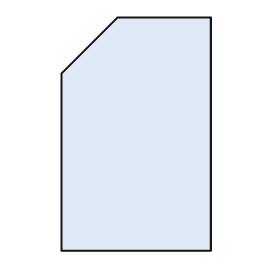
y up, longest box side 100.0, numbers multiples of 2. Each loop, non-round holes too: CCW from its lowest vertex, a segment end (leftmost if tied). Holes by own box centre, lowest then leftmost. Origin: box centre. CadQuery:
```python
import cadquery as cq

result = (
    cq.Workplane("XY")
    .moveTo(-32.0, -50.0)
    .lineTo(32.0, -50.0)
    .lineTo(32.0, 50.0)
    .lineTo(-8.0, 50.0)
    .lineTo(-32.0, 26.0)
    .close()
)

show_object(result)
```